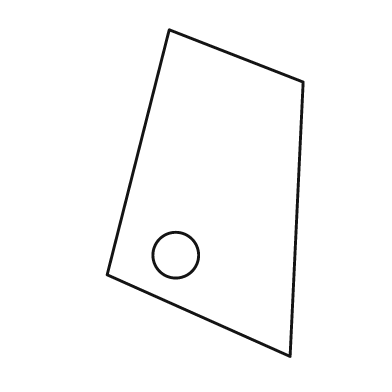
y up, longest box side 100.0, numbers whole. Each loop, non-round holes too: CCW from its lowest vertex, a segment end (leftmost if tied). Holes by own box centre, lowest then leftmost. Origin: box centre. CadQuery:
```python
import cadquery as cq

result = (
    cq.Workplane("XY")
    .moveTo(26.0, -50.0)
    .lineTo(30.0, 34.0)
    .lineTo(-11.0, 50.0)
    .lineTo(-30.0, -25.0)
    .close()
    .moveTo(-9.0, -19.0)
    .circle(7.0)
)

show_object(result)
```